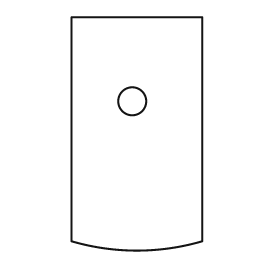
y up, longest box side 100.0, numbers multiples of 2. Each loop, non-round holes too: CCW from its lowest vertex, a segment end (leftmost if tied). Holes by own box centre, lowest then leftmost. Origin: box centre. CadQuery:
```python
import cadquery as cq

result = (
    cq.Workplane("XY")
    .moveTo(-28.0, -46.0)
    .threePointArc((0.0, -50.0), (28.0, -46.0))
    .lineTo(28.0, 50.0)
    .lineTo(-28.0, 50.0)
    .close()
    .moveTo(-2.0, 14.0)
    .circle(6.0)
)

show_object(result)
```